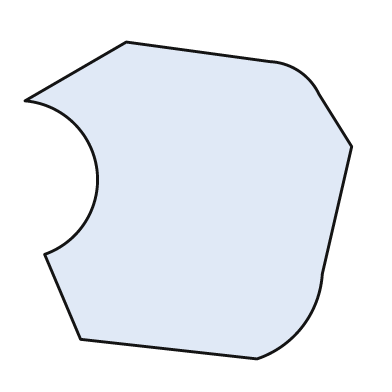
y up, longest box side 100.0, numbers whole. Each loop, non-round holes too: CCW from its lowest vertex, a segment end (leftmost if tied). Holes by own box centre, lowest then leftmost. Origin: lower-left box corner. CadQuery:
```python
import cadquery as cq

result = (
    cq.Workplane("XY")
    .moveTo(71.0, 0.0)
    .threePointArc((85.0, 10.0), (91.0, 26.0))
    .lineTo(100.0, 65.0)
    .lineTo(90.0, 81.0)
    .threePointArc((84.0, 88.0), (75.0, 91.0))
    .lineTo(31.0, 97.0)
    .lineTo(0.0, 79.0)
    .threePointArc((22.0, 58.0), (6.0, 32.0))
    .lineTo(17.0, 6.0)
    .close()
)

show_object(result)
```